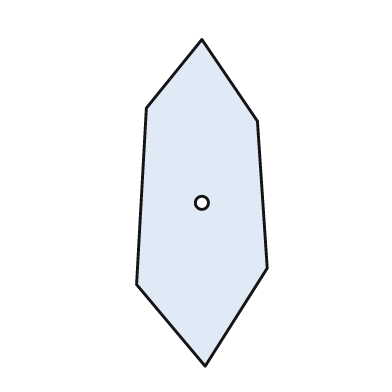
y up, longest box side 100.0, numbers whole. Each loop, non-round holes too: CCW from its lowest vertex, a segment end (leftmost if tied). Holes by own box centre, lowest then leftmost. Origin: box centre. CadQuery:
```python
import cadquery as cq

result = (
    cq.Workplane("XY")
    .moveTo(1.0, -50.0)
    .lineTo(20.0, -20.0)
    .lineTo(17.0, 25.0)
    .lineTo(0.0, 50.0)
    .lineTo(-17.0, 29.0)
    .lineTo(-20.0, -25.0)
    .close()
    .moveTo(0.0, 0.0)
    .circle(2.0)
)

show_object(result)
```